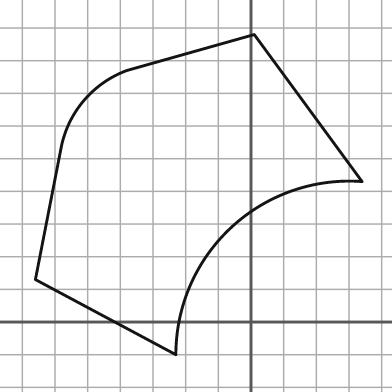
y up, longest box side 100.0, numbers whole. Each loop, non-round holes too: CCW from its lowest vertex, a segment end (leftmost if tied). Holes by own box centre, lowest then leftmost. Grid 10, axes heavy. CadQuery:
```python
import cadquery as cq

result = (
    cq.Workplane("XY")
    .moveTo(-23.0, -10.0)
    .threePointArc((-6.0, 29.0), (34.0, 43.0))
    .lineTo(1.0, 88.0)
    .lineTo(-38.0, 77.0)
    .threePointArc((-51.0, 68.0), (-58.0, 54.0))
    .lineTo(-66.0, 13.0)
    .close()
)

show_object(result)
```